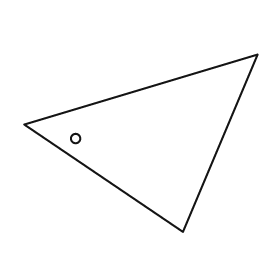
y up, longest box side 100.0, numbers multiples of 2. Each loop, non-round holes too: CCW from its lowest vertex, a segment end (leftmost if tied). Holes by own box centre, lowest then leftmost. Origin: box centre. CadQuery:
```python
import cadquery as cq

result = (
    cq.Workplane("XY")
    .moveTo(18.0, -38.0)
    .lineTo(50.0, 38.0)
    .lineTo(-50.0, 8.0)
    .close()
    .moveTo(-28.0, 2.0)
    .circle(2.0)
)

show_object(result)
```